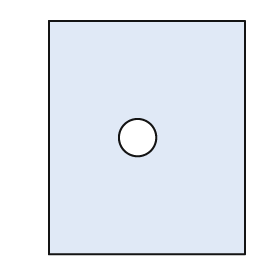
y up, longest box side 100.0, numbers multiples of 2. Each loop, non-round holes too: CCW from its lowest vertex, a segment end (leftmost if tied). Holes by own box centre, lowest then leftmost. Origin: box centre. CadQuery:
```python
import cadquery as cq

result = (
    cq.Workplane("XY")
    .moveTo(-42.0, -50.0)
    .lineTo(42.0, -50.0)
    .lineTo(42.0, 50.0)
    .lineTo(-42.0, 50.0)
    .close()
    .moveTo(-4.0, 0.0)
    .circle(8.0)
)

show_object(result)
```